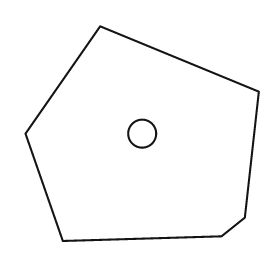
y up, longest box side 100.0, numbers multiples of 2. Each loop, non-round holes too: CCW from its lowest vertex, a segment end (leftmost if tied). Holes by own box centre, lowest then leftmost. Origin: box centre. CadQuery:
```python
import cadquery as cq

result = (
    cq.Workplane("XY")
    .moveTo(-34.0, -46.0)
    .lineTo(34.0, -44.0)
    .lineTo(44.0, -36.0)
    .lineTo(50.0, 18.0)
    .lineTo(-18.0, 46.0)
    .lineTo(-50.0, 0.0)
    .close()
    .moveTo(0.0, 0.0)
    .circle(6.0)
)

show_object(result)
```